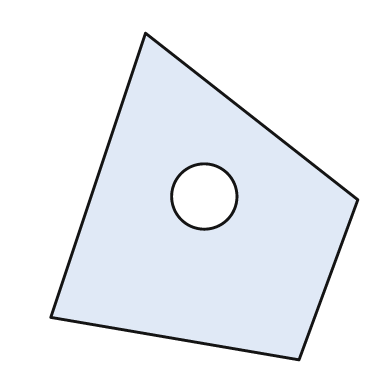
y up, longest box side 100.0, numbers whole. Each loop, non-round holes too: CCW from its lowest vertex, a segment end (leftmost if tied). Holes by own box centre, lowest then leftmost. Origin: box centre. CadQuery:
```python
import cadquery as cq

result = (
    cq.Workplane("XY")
    .moveTo(29.0, -50.0)
    .lineTo(47.0, -1.0)
    .lineTo(-18.0, 50.0)
    .lineTo(-47.0, -37.0)
    .close()
    .moveTo(0.0, 0.0)
    .circle(10.0)
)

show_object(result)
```